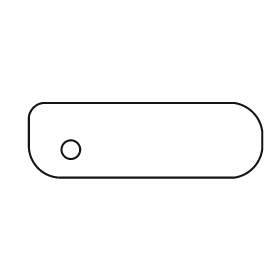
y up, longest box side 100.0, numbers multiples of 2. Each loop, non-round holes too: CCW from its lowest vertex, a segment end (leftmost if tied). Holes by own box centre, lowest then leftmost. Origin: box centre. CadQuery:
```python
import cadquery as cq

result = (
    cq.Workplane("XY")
    .moveTo(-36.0, -16.0)
    .lineTo(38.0, -16.0)
    .threePointArc((46.0, -12.0), (50.0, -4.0))
    .lineTo(50.0, 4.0)
    .threePointArc((46.0, 12.0), (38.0, 16.0))
    .lineTo(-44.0, 16.0)
    .threePointArc((-48.0, 14.0), (-50.0, 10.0))
    .lineTo(-50.0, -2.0)
    .threePointArc((-46.0, -12.0), (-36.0, -16.0))
    .close()
    .moveTo(-32.0, -4.0)
    .circle(4.0)
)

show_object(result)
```